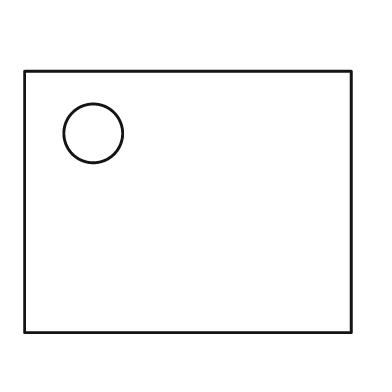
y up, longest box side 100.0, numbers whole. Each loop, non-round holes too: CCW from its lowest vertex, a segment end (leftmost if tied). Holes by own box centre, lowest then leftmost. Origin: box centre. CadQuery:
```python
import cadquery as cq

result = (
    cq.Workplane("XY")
    .moveTo(-50.0, -40.0)
    .lineTo(50.0, -40.0)
    .lineTo(50.0, 40.0)
    .lineTo(-50.0, 40.0)
    .close()
    .moveTo(-29.0, 21.0)
    .circle(9.0)
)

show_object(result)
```